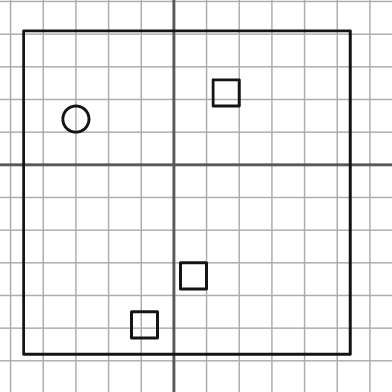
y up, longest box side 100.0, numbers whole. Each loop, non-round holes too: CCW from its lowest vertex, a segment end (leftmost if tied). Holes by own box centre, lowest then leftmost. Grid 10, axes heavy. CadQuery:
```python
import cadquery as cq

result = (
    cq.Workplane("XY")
    .moveTo(-46.0, -58.0)
    .lineTo(54.0, -58.0)
    .lineTo(54.0, 41.0)
    .lineTo(-46.0, 41.0)
    .close()
    .moveTo(-13.0, -53.0)
    .lineTo(-5.0, -53.0)
    .lineTo(-5.0, -45.0)
    .lineTo(-13.0, -45.0)
    .close()
    .moveTo(2.0, -38.0)
    .lineTo(10.0, -38.0)
    .lineTo(10.0, -30.0)
    .lineTo(2.0, -30.0)
    .close()
    .moveTo(-30.0, 14.0)
    .circle(4.0)
    .moveTo(12.0, 18.0)
    .lineTo(20.0, 18.0)
    .lineTo(20.0, 26.0)
    .lineTo(12.0, 26.0)
    .close()
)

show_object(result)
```